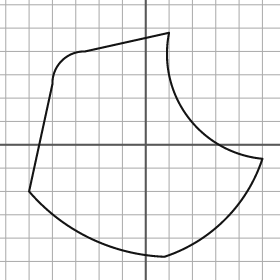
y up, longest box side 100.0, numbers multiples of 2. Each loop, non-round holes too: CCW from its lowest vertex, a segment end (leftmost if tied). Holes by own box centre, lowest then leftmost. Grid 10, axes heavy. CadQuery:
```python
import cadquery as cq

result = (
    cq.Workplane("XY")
    .moveTo(8.0, -48.0)
    .threePointArc((34.0, -32.0), (50.0, -6.0))
    .threePointArc((18.0, 12.0), (10.0, 48.0))
    .lineTo(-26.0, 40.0)
    .threePointArc((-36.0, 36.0), (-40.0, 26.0))
    .lineTo(-50.0, -20.0)
    .threePointArc((-24.0, -40.0), (8.0, -48.0))
    .close()
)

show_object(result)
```